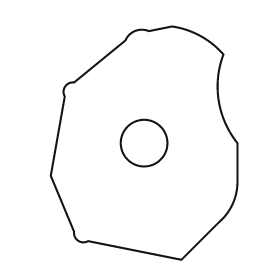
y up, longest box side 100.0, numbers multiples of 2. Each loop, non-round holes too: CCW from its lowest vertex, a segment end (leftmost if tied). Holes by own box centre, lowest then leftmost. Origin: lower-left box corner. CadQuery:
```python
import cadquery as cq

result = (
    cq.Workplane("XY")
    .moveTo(56.0, 0.0)
    .lineTo(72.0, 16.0)
    .threePointArc((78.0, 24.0), (80.0, 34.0))
    .lineTo(80.0, 50.0)
    .threePointArc((72.0, 68.0), (74.0, 88.0))
    .threePointArc((64.0, 96.0), (52.0, 100.0))
    .lineTo(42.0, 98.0)
    .threePointArc((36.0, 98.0), (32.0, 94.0))
    .lineTo(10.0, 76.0)
    .threePointArc((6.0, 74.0), (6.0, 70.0))
    .lineTo(0.0, 36.0)
    .lineTo(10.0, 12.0)
    .threePointArc((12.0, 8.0), (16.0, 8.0))
    .close()
    .moveTo(40.0, 50.0)
    .circle(10.0)
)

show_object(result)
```